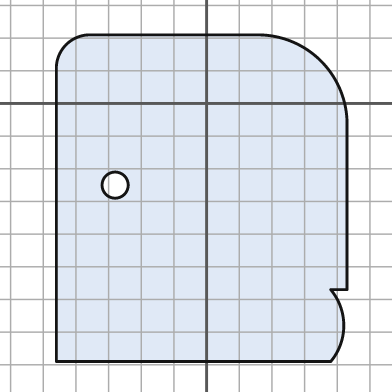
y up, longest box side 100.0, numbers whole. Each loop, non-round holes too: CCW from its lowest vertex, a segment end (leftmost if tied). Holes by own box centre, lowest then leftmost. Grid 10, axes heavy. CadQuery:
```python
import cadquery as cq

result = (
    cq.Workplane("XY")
    .moveTo(-46.0, -79.0)
    .lineTo(38.0, -79.0)
    .threePointArc((42.0, -68.0), (38.0, -57.0))
    .lineTo(43.0, -57.0)
    .lineTo(43.0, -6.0)
    .threePointArc((35.0, 13.0), (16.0, 21.0))
    .lineTo(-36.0, 21.0)
    .threePointArc((-43.0, 18.0), (-46.0, 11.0))
    .close()
    .moveTo(-28.0, -25.0)
    .circle(4.0)
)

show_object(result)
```